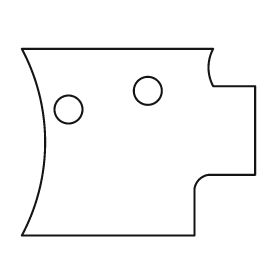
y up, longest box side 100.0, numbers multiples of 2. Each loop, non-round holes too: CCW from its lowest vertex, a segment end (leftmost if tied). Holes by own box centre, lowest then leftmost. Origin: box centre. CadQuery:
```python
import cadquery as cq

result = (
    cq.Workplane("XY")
    .moveTo(-50.0, -40.0)
    .lineTo(24.0, -40.0)
    .lineTo(24.0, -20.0)
    .threePointArc((26.0, -16.0), (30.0, -14.0))
    .lineTo(50.0, -14.0)
    .lineTo(50.0, 24.0)
    .lineTo(32.0, 24.0)
    .threePointArc((30.0, 32.0), (32.0, 40.0))
    .lineTo(-50.0, 40.0)
    .threePointArc((-40.0, 0.0), (-50.0, -40.0))
    .close()
    .moveTo(-30.0, 14.0)
    .circle(6.0)
    .moveTo(4.0, 22.0)
    .circle(6.0)
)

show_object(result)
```